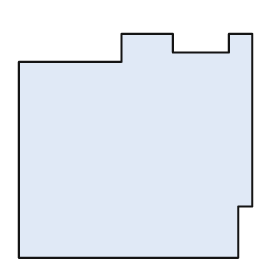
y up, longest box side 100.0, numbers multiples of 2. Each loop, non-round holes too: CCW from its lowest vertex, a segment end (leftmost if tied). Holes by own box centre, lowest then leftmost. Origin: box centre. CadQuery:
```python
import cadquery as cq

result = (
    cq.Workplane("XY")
    .moveTo(-50.0, -48.0)
    .lineTo(44.0, -48.0)
    .lineTo(44.0, -26.0)
    .lineTo(50.0, -26.0)
    .lineTo(50.0, 48.0)
    .lineTo(40.0, 48.0)
    .lineTo(40.0, 40.0)
    .lineTo(16.0, 40.0)
    .lineTo(16.0, 48.0)
    .lineTo(-6.0, 48.0)
    .lineTo(-6.0, 36.0)
    .lineTo(-50.0, 36.0)
    .close()
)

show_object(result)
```